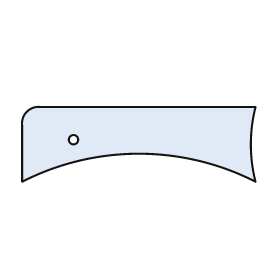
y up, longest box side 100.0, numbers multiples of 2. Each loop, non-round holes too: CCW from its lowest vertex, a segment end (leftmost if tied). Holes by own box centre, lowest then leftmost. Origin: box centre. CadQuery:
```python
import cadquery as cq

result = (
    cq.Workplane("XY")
    .moveTo(-50.0, -16.0)
    .threePointArc((0.0, -4.0), (50.0, -16.0))
    .threePointArc((48.0, 0.0), (50.0, 16.0))
    .lineTo(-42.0, 16.0)
    .threePointArc((-48.0, 14.0), (-50.0, 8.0))
    .close()
    .moveTo(-28.0, 2.0)
    .circle(2.0)
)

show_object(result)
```